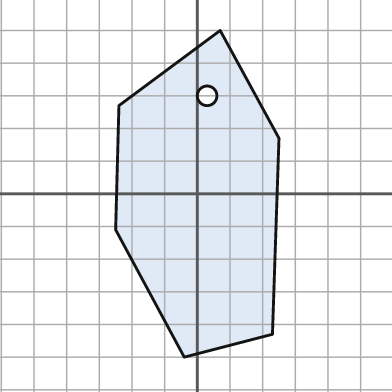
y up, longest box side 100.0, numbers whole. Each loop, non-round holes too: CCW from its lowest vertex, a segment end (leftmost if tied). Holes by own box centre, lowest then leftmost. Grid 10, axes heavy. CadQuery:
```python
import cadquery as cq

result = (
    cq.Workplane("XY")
    .moveTo(-4.0, -50.0)
    .lineTo(23.0, -43.0)
    .lineTo(25.0, 17.0)
    .lineTo(7.0, 50.0)
    .lineTo(-24.0, 27.0)
    .lineTo(-25.0, -11.0)
    .close()
    .moveTo(3.0, 30.0)
    .circle(3.0)
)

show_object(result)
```